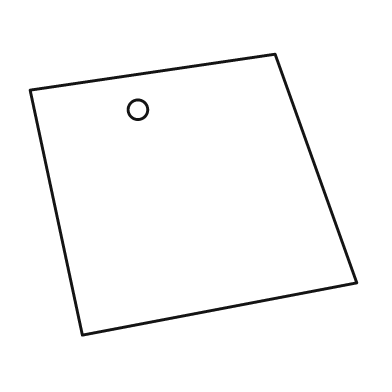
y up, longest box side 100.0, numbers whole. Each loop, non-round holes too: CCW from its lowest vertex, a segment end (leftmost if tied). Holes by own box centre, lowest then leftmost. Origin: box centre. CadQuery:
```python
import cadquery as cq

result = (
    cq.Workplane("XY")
    .moveTo(-34.0, -43.0)
    .lineTo(50.0, -27.0)
    .lineTo(25.0, 43.0)
    .lineTo(-50.0, 32.0)
    .close()
    .moveTo(-17.0, 26.0)
    .circle(3.0)
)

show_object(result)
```